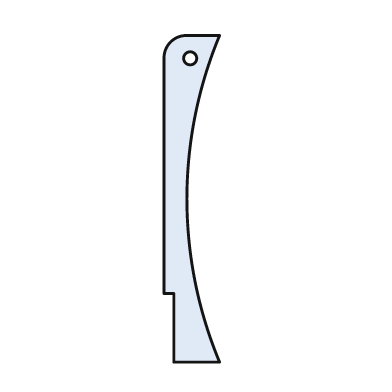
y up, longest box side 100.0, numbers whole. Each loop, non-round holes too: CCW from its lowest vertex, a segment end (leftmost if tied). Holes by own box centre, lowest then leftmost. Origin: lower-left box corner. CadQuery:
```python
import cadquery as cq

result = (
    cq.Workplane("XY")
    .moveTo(3.0, 0.0)
    .lineTo(17.0, 0.0)
    .threePointArc((7.0, 50.0), (17.0, 100.0))
    .lineTo(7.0, 100.0)
    .threePointArc((2.0, 98.0), (0.0, 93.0))
    .lineTo(0.0, 21.0)
    .lineTo(3.0, 21.0)
    .close()
    .moveTo(8.0, 93.0)
    .circle(2.0)
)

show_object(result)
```